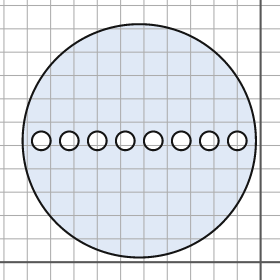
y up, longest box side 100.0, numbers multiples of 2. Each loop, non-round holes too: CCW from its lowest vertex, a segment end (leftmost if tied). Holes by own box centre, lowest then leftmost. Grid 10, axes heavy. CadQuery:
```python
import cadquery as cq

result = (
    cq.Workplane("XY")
    .moveTo(-52.0, 52.0)
    .circle(50.0)
    .moveTo(-94.0, 52.0)
    .circle(4.0)
    .moveTo(-82.0, 52.0)
    .circle(4.0)
    .moveTo(-70.0, 52.0)
    .circle(4.0)
    .moveTo(-58.0, 52.0)
    .circle(4.0)
    .moveTo(-46.0, 52.0)
    .circle(4.0)
    .moveTo(-34.0, 52.0)
    .circle(4.0)
    .moveTo(-22.0, 52.0)
    .circle(4.0)
    .moveTo(-10.0, 52.0)
    .circle(4.0)
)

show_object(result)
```